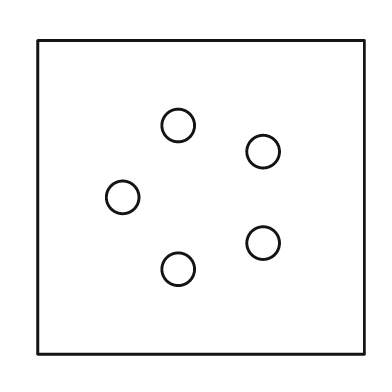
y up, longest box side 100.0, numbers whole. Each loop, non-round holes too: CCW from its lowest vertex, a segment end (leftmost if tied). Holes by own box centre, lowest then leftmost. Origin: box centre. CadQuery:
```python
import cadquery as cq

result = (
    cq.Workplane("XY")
    .moveTo(-50.0, -48.0)
    .lineTo(50.0, -48.0)
    .lineTo(50.0, 48.0)
    .lineTo(-50.0, 48.0)
    .close()
    .moveTo(-7.0, -22.0)
    .circle(5.0)
    .moveTo(19.0, -14.0)
    .circle(5.0)
    .moveTo(-24.0, 0.0)
    .circle(5.0)
    .moveTo(19.0, 14.0)
    .circle(5.0)
    .moveTo(-7.0, 22.0)
    .circle(5.0)
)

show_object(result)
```